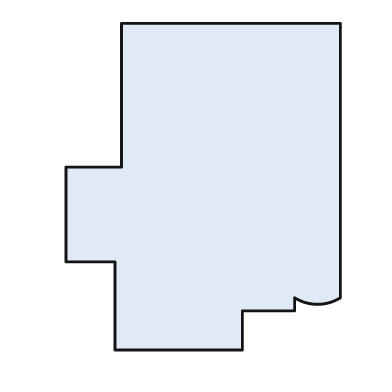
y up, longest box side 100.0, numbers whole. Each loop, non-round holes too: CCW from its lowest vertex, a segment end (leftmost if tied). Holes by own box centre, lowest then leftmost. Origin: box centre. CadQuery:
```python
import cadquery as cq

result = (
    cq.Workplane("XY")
    .moveTo(-27.0, -50.0)
    .lineTo(12.0, -50.0)
    .lineTo(12.0, -38.0)
    .lineTo(28.0, -38.0)
    .lineTo(28.0, -34.0)
    .threePointArc((35.0, -36.0), (42.0, -34.0))
    .lineTo(42.0, 50.0)
    .lineTo(-25.0, 50.0)
    .lineTo(-25.0, 6.0)
    .lineTo(-42.0, 6.0)
    .lineTo(-42.0, -23.0)
    .lineTo(-27.0, -23.0)
    .close()
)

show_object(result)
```